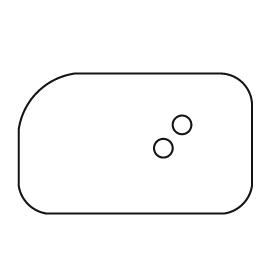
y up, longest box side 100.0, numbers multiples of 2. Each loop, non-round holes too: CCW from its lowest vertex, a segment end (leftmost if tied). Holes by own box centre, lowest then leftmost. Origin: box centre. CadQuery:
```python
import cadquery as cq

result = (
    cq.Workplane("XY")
    .moveTo(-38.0, -30.0)
    .lineTo(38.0, -30.0)
    .threePointArc((46.0, -26.0), (50.0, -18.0))
    .lineTo(50.0, 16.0)
    .threePointArc((46.0, 26.0), (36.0, 30.0))
    .lineTo(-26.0, 30.0)
    .threePointArc((-42.0, 22.0), (-50.0, 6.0))
    .lineTo(-50.0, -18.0)
    .threePointArc((-46.0, -26.0), (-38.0, -30.0))
    .close()
    .moveTo(12.0, -2.0)
    .circle(4.0)
    .moveTo(20.0, 8.0)
    .circle(4.0)
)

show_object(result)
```